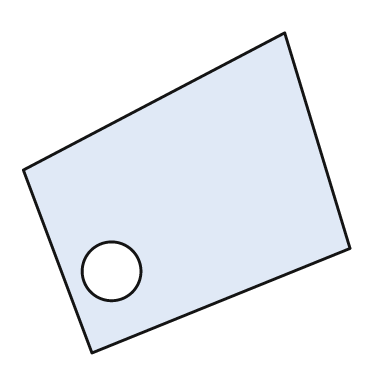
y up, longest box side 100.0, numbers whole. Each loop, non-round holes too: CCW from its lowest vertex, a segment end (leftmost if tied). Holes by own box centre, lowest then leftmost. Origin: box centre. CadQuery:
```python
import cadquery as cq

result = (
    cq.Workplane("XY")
    .moveTo(-29.0, -49.0)
    .lineTo(50.0, -17.0)
    .lineTo(30.0, 49.0)
    .lineTo(-50.0, 7.0)
    .close()
    .moveTo(-23.0, -24.0)
    .circle(9.0)
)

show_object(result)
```